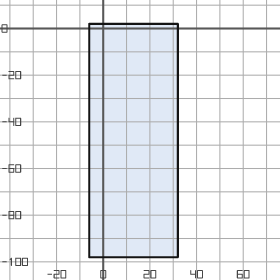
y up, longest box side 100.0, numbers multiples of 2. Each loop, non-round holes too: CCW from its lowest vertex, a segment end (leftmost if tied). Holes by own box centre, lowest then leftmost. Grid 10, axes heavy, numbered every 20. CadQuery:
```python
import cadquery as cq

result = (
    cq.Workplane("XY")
    .moveTo(-6.0, -98.0)
    .lineTo(32.0, -98.0)
    .lineTo(32.0, 2.0)
    .lineTo(-6.0, 2.0)
    .close()
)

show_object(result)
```